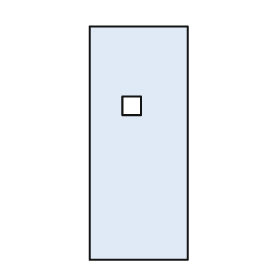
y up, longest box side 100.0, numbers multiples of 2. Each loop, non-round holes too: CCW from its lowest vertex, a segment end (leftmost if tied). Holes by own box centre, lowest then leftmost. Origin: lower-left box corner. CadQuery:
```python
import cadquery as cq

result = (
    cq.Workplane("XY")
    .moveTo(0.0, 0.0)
    .lineTo(42.0, 0.0)
    .lineTo(42.0, 100.0)
    .lineTo(0.0, 100.0)
    .close()
    .moveTo(14.0, 62.0)
    .lineTo(22.0, 62.0)
    .lineTo(22.0, 70.0)
    .lineTo(14.0, 70.0)
    .close()
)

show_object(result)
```